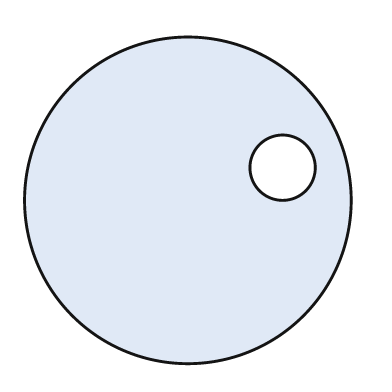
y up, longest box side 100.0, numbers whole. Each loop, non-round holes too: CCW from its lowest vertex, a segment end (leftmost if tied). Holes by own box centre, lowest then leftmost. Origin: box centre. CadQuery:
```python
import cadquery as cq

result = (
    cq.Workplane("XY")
    .moveTo(0.0, 0.0)
    .circle(50.0)
    .moveTo(29.0, 10.0)
    .circle(10.0)
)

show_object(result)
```